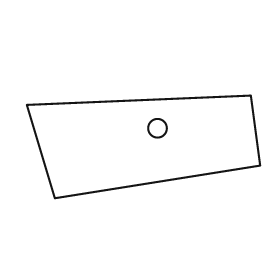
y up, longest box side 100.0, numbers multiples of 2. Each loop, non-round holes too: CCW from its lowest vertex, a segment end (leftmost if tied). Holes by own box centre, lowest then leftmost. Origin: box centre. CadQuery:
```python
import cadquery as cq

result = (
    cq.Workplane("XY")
    .moveTo(-38.0, -22.0)
    .lineTo(50.0, -8.0)
    .lineTo(46.0, 22.0)
    .lineTo(-50.0, 18.0)
    .close()
    .moveTo(6.0, 8.0)
    .circle(4.0)
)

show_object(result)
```